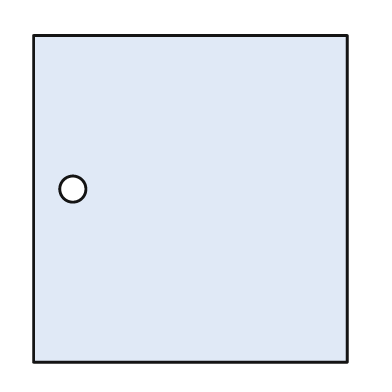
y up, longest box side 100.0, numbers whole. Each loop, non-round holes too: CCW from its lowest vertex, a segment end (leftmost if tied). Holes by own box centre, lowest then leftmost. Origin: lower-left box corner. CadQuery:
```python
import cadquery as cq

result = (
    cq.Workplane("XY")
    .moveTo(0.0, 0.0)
    .lineTo(96.0, 0.0)
    .lineTo(96.0, 100.0)
    .lineTo(0.0, 100.0)
    .close()
    .moveTo(12.0, 53.0)
    .circle(4.0)
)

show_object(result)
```